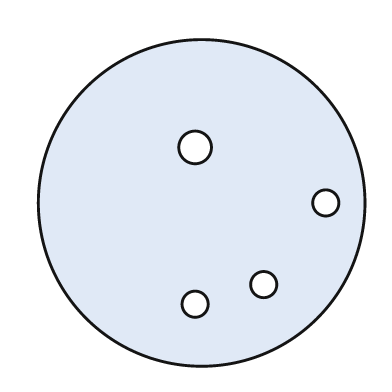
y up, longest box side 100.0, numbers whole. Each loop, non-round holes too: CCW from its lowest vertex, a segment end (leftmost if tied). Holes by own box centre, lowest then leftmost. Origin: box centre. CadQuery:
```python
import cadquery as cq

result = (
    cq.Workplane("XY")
    .moveTo(0.0, 0.0)
    .circle(50.0)
    .moveTo(-2.0, -31.0)
    .circle(4.0)
    .moveTo(19.0, -25.0)
    .circle(4.0)
    .moveTo(38.0, 0.0)
    .circle(4.0)
    .moveTo(-2.0, 17.0)
    .circle(5.0)
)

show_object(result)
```